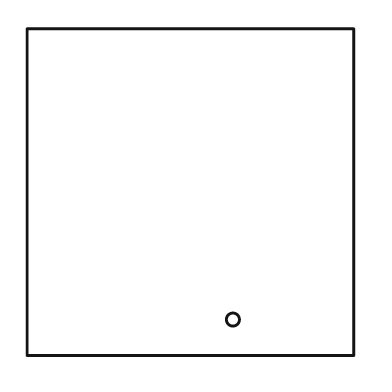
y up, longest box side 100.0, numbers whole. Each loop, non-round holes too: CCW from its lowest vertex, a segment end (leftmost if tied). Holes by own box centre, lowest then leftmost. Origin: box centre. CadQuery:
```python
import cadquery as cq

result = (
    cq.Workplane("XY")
    .moveTo(-50.0, -50.0)
    .lineTo(50.0, -50.0)
    .lineTo(50.0, 50.0)
    .lineTo(-50.0, 50.0)
    .close()
    .moveTo(13.0, -39.0)
    .circle(2.0)
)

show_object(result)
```